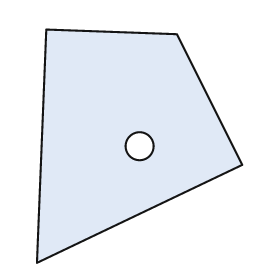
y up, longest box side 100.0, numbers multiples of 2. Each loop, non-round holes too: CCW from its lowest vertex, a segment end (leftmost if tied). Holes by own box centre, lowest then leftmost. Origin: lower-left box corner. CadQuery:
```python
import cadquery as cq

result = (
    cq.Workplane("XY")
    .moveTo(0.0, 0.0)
    .lineTo(88.0, 42.0)
    .lineTo(60.0, 98.0)
    .lineTo(4.0, 100.0)
    .close()
    .moveTo(44.0, 50.0)
    .circle(6.0)
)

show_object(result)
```